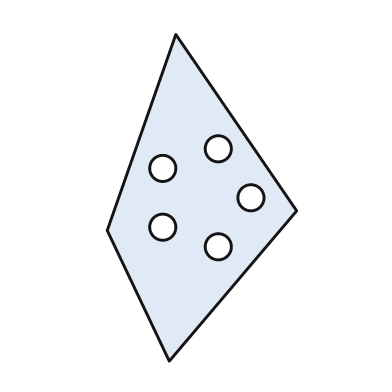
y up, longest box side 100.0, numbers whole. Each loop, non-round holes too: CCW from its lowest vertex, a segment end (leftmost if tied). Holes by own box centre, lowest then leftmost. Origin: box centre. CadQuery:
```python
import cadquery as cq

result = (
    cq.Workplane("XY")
    .moveTo(-10.0, -50.0)
    .lineTo(29.0, -4.0)
    .lineTo(-8.0, 50.0)
    .lineTo(-29.0, -10.0)
    .close()
    .moveTo(5.0, -15.0)
    .circle(4.0)
    .moveTo(-12.0, -9.0)
    .circle(4.0)
    .moveTo(15.0, 0.0)
    .circle(4.0)
    .moveTo(-12.0, 9.0)
    .circle(4.0)
    .moveTo(5.0, 15.0)
    .circle(4.0)
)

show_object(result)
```